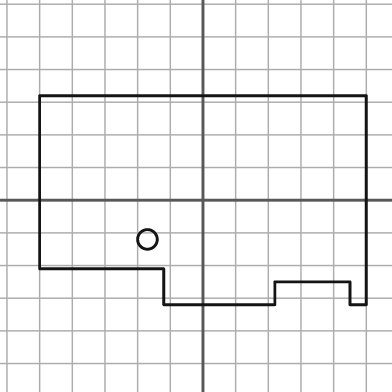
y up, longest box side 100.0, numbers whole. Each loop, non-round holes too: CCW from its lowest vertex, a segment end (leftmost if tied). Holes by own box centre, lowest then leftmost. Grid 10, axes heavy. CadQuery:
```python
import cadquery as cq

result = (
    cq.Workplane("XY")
    .moveTo(-12.0, -32.0)
    .lineTo(22.0, -32.0)
    .lineTo(22.0, -25.0)
    .lineTo(45.0, -25.0)
    .lineTo(45.0, -32.0)
    .lineTo(50.0, -32.0)
    .lineTo(50.0, 32.0)
    .lineTo(-50.0, 32.0)
    .lineTo(-50.0, -21.0)
    .lineTo(-12.0, -21.0)
    .close()
    .moveTo(-17.0, -12.0)
    .circle(3.0)
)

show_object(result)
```